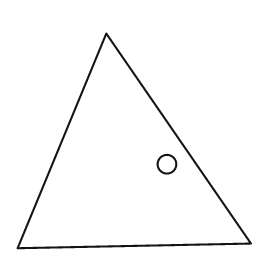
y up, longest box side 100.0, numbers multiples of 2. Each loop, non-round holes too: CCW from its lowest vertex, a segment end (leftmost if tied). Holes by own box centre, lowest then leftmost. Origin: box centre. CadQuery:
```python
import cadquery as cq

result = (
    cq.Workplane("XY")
    .moveTo(-50.0, -46.0)
    .lineTo(50.0, -44.0)
    .lineTo(-12.0, 46.0)
    .close()
    .moveTo(14.0, -10.0)
    .circle(4.0)
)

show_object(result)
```